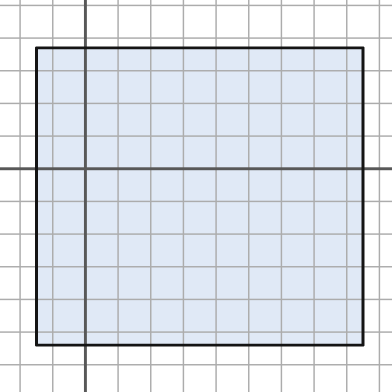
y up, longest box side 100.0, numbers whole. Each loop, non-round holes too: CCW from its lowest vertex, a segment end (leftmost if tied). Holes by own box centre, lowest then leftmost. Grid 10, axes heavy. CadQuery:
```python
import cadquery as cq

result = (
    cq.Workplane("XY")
    .moveTo(-15.0, -54.0)
    .lineTo(85.0, -54.0)
    .lineTo(85.0, 37.0)
    .lineTo(-15.0, 37.0)
    .close()
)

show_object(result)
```